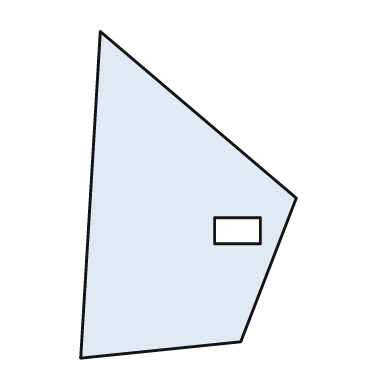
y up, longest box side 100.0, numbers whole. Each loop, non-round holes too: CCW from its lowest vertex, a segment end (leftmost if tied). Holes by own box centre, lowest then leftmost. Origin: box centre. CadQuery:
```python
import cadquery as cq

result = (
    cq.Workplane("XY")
    .moveTo(-33.0, -50.0)
    .lineTo(16.0, -45.0)
    .lineTo(33.0, -1.0)
    .lineTo(-27.0, 50.0)
    .close()
    .moveTo(8.0, -15.0)
    .lineTo(22.0, -15.0)
    .lineTo(22.0, -7.0)
    .lineTo(8.0, -7.0)
    .close()
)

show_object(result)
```